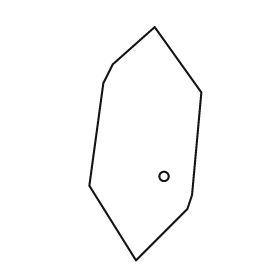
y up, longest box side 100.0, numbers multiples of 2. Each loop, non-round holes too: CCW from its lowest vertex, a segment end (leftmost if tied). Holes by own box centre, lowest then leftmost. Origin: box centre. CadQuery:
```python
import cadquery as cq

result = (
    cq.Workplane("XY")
    .moveTo(-4.0, -50.0)
    .lineTo(18.0, -28.0)
    .lineTo(20.0, -22.0)
    .lineTo(24.0, 22.0)
    .lineTo(4.0, 50.0)
    .lineTo(-14.0, 34.0)
    .lineTo(-18.0, 26.0)
    .lineTo(-24.0, -18.0)
    .close()
    .moveTo(8.0, -14.0)
    .circle(2.0)
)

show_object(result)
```